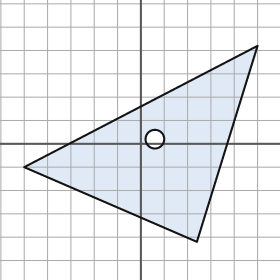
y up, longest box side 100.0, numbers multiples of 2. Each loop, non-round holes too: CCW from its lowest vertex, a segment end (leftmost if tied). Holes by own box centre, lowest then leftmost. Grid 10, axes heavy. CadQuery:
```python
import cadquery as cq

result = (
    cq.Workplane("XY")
    .moveTo(24.0, -42.0)
    .lineTo(50.0, 42.0)
    .lineTo(-50.0, -10.0)
    .close()
    .moveTo(6.0, 2.0)
    .circle(4.0)
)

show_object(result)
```